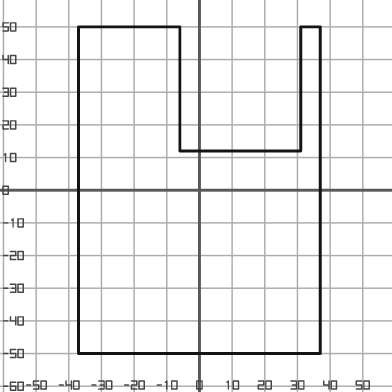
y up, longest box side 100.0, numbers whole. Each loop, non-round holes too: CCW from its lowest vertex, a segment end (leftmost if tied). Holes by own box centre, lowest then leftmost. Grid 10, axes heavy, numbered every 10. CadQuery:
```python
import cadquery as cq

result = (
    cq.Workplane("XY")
    .moveTo(-37.0, -50.0)
    .lineTo(37.0, -50.0)
    .lineTo(37.0, 50.0)
    .lineTo(31.0, 50.0)
    .lineTo(31.0, 12.0)
    .lineTo(-6.0, 12.0)
    .lineTo(-6.0, 50.0)
    .lineTo(-37.0, 50.0)
    .close()
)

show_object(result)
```